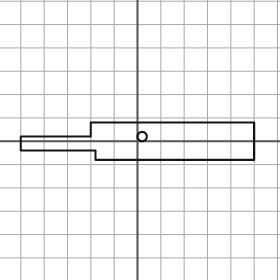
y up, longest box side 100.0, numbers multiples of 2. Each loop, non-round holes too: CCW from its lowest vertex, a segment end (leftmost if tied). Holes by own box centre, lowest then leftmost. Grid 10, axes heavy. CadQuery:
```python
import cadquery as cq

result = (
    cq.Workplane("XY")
    .moveTo(-18.0, -8.0)
    .lineTo(50.0, -8.0)
    .lineTo(50.0, 8.0)
    .lineTo(-20.0, 8.0)
    .lineTo(-20.0, 2.0)
    .lineTo(-50.0, 2.0)
    .lineTo(-50.0, -4.0)
    .lineTo(-18.0, -4.0)
    .close()
    .moveTo(2.0, 2.0)
    .circle(2.0)
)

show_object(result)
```